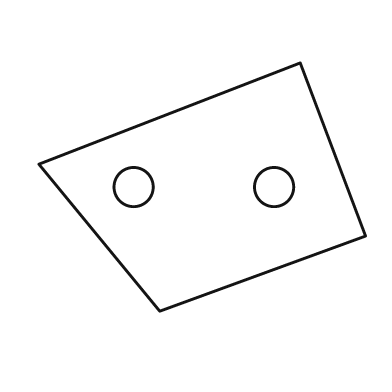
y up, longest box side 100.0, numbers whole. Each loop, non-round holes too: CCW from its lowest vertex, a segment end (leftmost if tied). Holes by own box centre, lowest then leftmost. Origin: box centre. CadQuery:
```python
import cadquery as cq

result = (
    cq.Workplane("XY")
    .moveTo(-13.0, -38.0)
    .lineTo(50.0, -15.0)
    .lineTo(30.0, 38.0)
    .lineTo(-50.0, 7.0)
    .close()
    .moveTo(-21.0, 0.0)
    .circle(6.0)
    .moveTo(22.0, 0.0)
    .circle(6.0)
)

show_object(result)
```